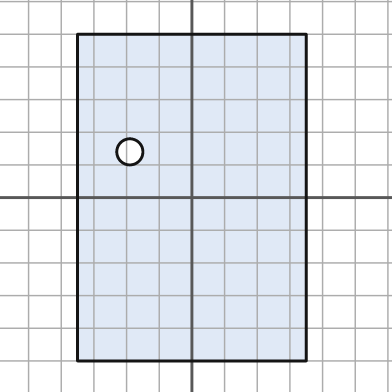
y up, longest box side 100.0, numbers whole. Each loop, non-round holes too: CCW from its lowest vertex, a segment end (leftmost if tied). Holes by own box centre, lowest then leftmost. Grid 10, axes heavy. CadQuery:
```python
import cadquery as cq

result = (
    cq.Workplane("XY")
    .moveTo(-35.0, -50.0)
    .lineTo(35.0, -50.0)
    .lineTo(35.0, 50.0)
    .lineTo(-35.0, 50.0)
    .close()
    .moveTo(-19.0, 14.0)
    .circle(4.0)
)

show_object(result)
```